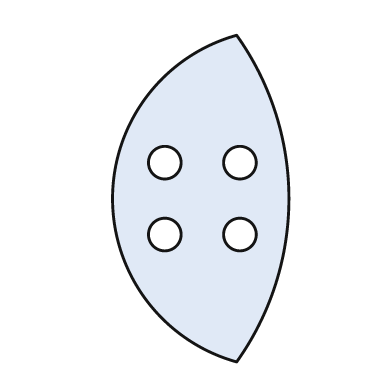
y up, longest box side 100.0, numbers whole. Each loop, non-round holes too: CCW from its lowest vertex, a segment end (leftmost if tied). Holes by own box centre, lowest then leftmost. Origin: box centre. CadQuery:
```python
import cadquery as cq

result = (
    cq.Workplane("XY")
    .moveTo(11.0, -50.0)
    .threePointArc((27.0, 0.0), (11.0, 50.0))
    .threePointArc((-27.0, 0.0), (11.0, -50.0))
    .close()
    .moveTo(-11.0, -11.0)
    .circle(5.0)
    .moveTo(12.0, -11.0)
    .circle(5.0)
    .moveTo(-11.0, 11.0)
    .circle(5.0)
    .moveTo(12.0, 11.0)
    .circle(5.0)
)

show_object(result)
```